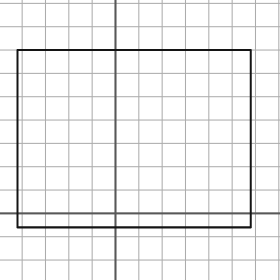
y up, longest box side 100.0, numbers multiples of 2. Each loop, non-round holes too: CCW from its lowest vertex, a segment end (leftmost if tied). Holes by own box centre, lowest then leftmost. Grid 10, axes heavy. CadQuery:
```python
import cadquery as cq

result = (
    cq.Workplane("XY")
    .moveTo(-42.0, -6.0)
    .lineTo(58.0, -6.0)
    .lineTo(58.0, 70.0)
    .lineTo(-42.0, 70.0)
    .close()
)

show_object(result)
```